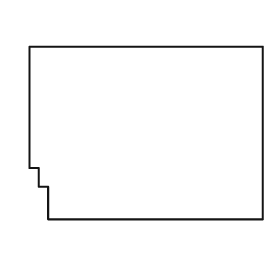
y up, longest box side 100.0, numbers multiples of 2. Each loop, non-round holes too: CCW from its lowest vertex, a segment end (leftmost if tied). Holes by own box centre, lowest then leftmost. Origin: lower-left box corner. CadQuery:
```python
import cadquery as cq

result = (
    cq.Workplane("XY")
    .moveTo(8.0, 0.0)
    .lineTo(100.0, 0.0)
    .lineTo(100.0, 74.0)
    .lineTo(0.0, 74.0)
    .lineTo(0.0, 22.0)
    .lineTo(4.0, 22.0)
    .lineTo(4.0, 14.0)
    .lineTo(8.0, 14.0)
    .close()
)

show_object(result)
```